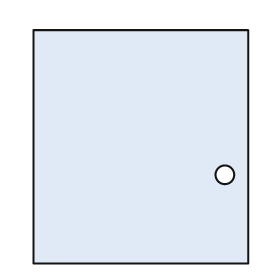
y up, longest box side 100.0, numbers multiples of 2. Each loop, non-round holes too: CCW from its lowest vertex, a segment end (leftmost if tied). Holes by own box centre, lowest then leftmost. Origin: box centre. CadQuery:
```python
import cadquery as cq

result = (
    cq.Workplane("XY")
    .moveTo(-46.0, -50.0)
    .lineTo(46.0, -50.0)
    .lineTo(46.0, 50.0)
    .lineTo(-46.0, 50.0)
    .close()
    .moveTo(36.0, -12.0)
    .circle(4.0)
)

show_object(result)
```